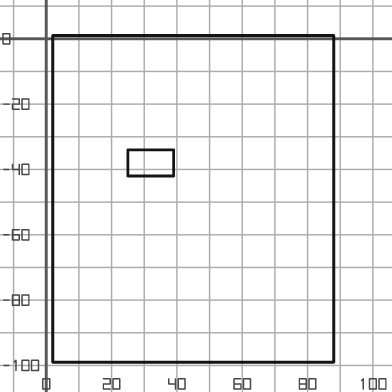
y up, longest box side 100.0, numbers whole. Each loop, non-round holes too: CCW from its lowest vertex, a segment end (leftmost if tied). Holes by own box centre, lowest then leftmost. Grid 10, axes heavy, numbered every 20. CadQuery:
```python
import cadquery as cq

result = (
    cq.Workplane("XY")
    .moveTo(2.0, -99.0)
    .lineTo(88.0, -99.0)
    .lineTo(88.0, 1.0)
    .lineTo(2.0, 1.0)
    .close()
    .moveTo(25.0, -42.0)
    .lineTo(39.0, -42.0)
    .lineTo(39.0, -34.0)
    .lineTo(25.0, -34.0)
    .close()
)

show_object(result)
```